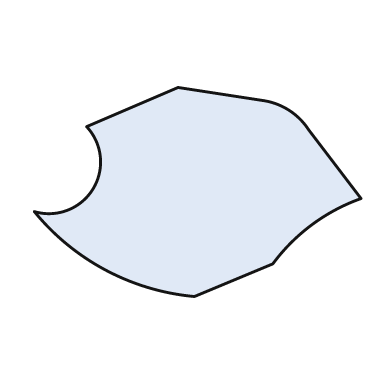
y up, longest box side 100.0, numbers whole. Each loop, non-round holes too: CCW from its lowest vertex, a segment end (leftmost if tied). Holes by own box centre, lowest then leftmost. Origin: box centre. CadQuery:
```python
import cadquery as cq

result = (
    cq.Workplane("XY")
    .moveTo(-1.0, -32.0)
    .lineTo(23.0, -22.0)
    .threePointArc((35.0, -10.0), (50.0, -2.0))
    .lineTo(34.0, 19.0)
    .threePointArc((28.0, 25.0), (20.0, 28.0))
    .lineTo(-6.0, 32.0)
    .lineTo(-34.0, 20.0)
    .threePointArc((-32.0, 1.0), (-50.0, -6.0))
    .threePointArc((-28.0, -24.0), (-1.0, -32.0))
    .close()
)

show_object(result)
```